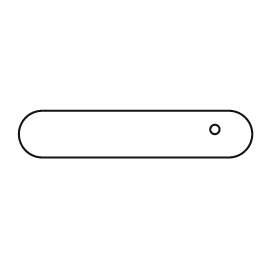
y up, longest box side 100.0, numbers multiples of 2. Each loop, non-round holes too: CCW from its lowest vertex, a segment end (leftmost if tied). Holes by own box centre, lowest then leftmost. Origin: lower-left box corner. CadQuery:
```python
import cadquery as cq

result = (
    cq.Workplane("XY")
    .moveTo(10.0, 0.0)
    .lineTo(90.0, 0.0)
    .threePointArc((100.0, 10.0), (90.0, 20.0))
    .lineTo(10.0, 20.0)
    .threePointArc((0.0, 10.0), (10.0, 0.0))
    .close()
    .moveTo(84.0, 12.0)
    .circle(2.0)
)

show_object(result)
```